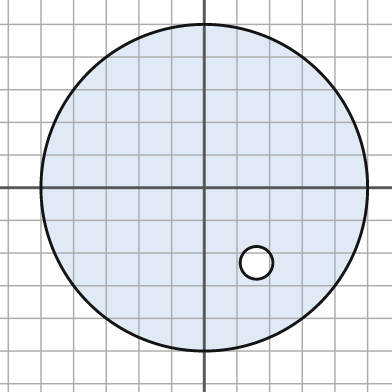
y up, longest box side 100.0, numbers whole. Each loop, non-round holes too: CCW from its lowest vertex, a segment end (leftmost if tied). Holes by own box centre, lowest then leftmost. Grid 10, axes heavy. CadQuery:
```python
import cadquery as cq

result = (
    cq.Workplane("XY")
    .moveTo(0.0, 0.0)
    .circle(50.0)
    .moveTo(16.0, -23.0)
    .circle(5.0)
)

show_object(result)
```